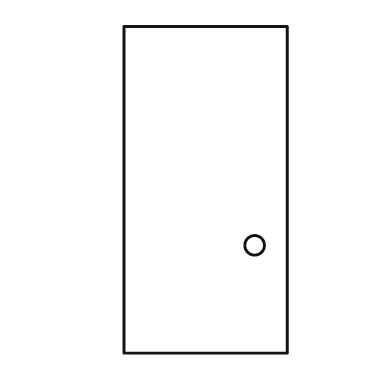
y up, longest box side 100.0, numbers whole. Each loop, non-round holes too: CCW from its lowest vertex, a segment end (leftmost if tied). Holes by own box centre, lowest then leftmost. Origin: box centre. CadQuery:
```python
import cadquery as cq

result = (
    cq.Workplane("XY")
    .moveTo(-25.0, -50.0)
    .lineTo(25.0, -50.0)
    .lineTo(25.0, 50.0)
    .lineTo(-25.0, 50.0)
    .close()
    .moveTo(15.0, -17.0)
    .circle(3.0)
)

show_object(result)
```